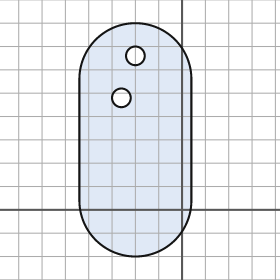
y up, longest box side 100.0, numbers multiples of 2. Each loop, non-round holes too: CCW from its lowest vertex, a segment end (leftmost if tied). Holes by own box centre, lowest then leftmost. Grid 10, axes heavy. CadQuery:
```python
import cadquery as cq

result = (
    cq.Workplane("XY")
    .moveTo(-44.0, 4.0)
    .threePointArc((-20.0, -20.0), (4.0, 4.0))
    .lineTo(4.0, 56.0)
    .threePointArc((-20.0, 80.0), (-44.0, 56.0))
    .close()
    .moveTo(-26.0, 48.0)
    .circle(4.0)
    .moveTo(-20.0, 66.0)
    .circle(4.0)
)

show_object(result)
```